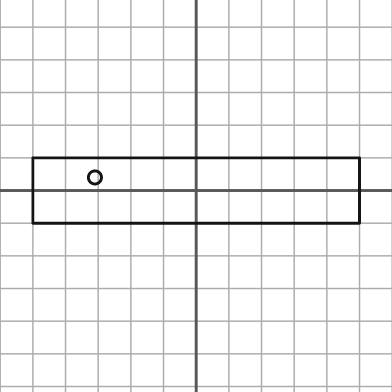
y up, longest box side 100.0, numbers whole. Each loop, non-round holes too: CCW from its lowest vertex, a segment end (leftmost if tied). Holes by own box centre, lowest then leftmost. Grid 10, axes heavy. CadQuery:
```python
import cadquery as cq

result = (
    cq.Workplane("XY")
    .moveTo(-50.0, -10.0)
    .lineTo(50.0, -10.0)
    .lineTo(50.0, 10.0)
    .lineTo(-50.0, 10.0)
    .close()
    .moveTo(-31.0, 4.0)
    .circle(2.0)
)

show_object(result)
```